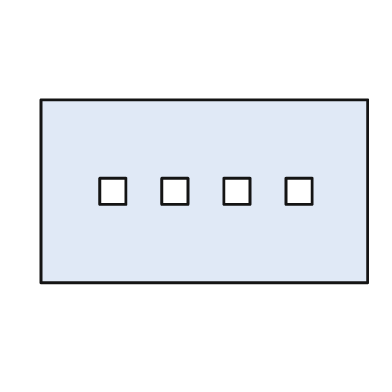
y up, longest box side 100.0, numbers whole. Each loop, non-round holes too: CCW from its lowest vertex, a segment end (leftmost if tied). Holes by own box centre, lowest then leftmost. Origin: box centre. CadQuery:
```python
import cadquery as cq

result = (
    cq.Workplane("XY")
    .moveTo(-50.0, -28.0)
    .lineTo(50.0, -28.0)
    .lineTo(50.0, 28.0)
    .lineTo(-50.0, 28.0)
    .close()
    .moveTo(-32.0, -4.0)
    .lineTo(-24.0, -4.0)
    .lineTo(-24.0, 4.0)
    .lineTo(-32.0, 4.0)
    .close()
    .moveTo(-13.0, -4.0)
    .lineTo(-5.0, -4.0)
    .lineTo(-5.0, 4.0)
    .lineTo(-13.0, 4.0)
    .close()
    .moveTo(6.0, -4.0)
    .lineTo(14.0, -4.0)
    .lineTo(14.0, 4.0)
    .lineTo(6.0, 4.0)
    .close()
    .moveTo(25.0, -4.0)
    .lineTo(33.0, -4.0)
    .lineTo(33.0, 4.0)
    .lineTo(25.0, 4.0)
    .close()
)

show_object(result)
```